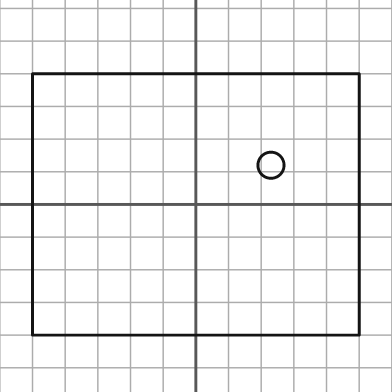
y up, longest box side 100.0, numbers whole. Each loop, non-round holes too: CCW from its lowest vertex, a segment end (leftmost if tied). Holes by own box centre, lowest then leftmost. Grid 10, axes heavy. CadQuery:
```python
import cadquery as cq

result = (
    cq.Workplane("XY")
    .moveTo(-50.0, -40.0)
    .lineTo(50.0, -40.0)
    .lineTo(50.0, 40.0)
    .lineTo(-50.0, 40.0)
    .close()
    .moveTo(23.0, 12.0)
    .circle(4.0)
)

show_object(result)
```